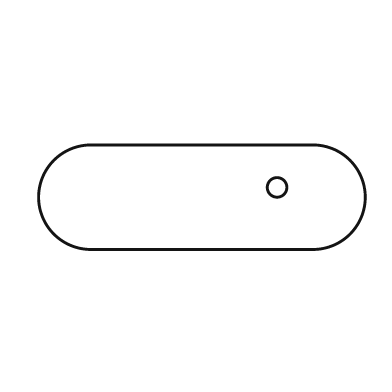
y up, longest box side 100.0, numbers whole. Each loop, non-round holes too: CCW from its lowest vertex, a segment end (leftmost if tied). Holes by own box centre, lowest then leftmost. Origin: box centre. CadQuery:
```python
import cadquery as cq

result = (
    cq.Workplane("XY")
    .moveTo(-34.0, -16.0)
    .lineTo(34.0, -16.0)
    .threePointArc((50.0, 0.0), (34.0, 16.0))
    .lineTo(-34.0, 16.0)
    .threePointArc((-50.0, 0.0), (-34.0, -16.0))
    .close()
    .moveTo(23.0, 3.0)
    .circle(3.0)
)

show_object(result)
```